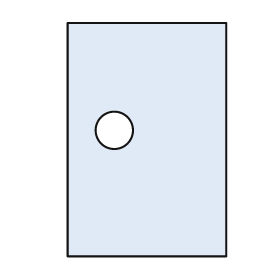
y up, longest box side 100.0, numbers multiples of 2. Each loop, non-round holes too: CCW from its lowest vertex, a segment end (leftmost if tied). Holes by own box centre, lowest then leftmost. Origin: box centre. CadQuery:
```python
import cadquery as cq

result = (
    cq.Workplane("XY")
    .moveTo(-34.0, -50.0)
    .lineTo(34.0, -50.0)
    .lineTo(34.0, 50.0)
    .lineTo(-34.0, 50.0)
    .close()
    .moveTo(-14.0, 4.0)
    .circle(8.0)
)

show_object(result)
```